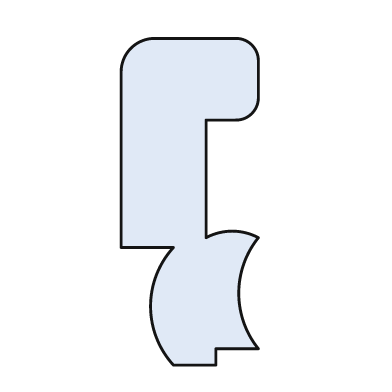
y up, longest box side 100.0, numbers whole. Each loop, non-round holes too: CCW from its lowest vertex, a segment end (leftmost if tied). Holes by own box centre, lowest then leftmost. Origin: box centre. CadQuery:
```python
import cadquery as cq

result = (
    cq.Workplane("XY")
    .moveTo(-5.0, -50.0)
    .lineTo(8.0, -50.0)
    .lineTo(8.0, -45.0)
    .lineTo(21.0, -45.0)
    .threePointArc((15.0, -28.0), (21.0, -11.0))
    .threePointArc((13.0, -9.0), (5.0, -11.0))
    .lineTo(5.0, 25.0)
    .lineTo(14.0, 25.0)
    .threePointArc((19.0, 27.0), (21.0, 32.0))
    .lineTo(21.0, 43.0)
    .threePointArc((19.0, 48.0), (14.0, 50.0))
    .lineTo(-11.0, 50.0)
    .threePointArc((-18.0, 47.0), (-21.0, 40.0))
    .lineTo(-21.0, -14.0)
    .lineTo(-5.0, -14.0)
    .threePointArc((-12.0, -32.0), (-5.0, -50.0))
    .close()
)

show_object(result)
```